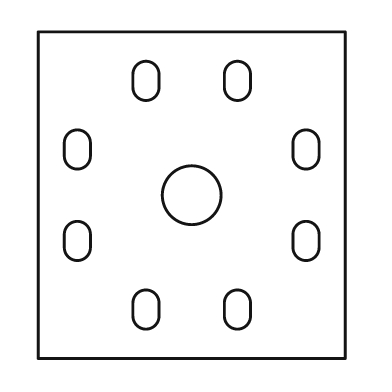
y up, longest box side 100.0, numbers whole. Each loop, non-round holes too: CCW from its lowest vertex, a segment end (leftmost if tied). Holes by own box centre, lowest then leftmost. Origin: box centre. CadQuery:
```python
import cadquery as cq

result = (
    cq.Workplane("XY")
    .moveTo(-47.0, -50.0)
    .lineTo(47.0, -50.0)
    .lineTo(47.0, 50.0)
    .lineTo(-47.0, 50.0)
    .close()
    .moveTo(-18.0, -37.0)
    .threePointArc((-14.0, -41.0), (-10.0, -37.0))
    .lineTo(-10.0, -33.0)
    .threePointArc((-14.0, -29.0), (-18.0, -33.0))
    .close()
    .moveTo(10.0, -37.0)
    .threePointArc((14.0, -41.0), (18.0, -37.0))
    .lineTo(18.0, -33.0)
    .threePointArc((14.0, -29.0), (10.0, -33.0))
    .close()
    .moveTo(-39.0, -16.0)
    .threePointArc((-35.0, -20.0), (-31.0, -16.0))
    .lineTo(-31.0, -12.0)
    .threePointArc((-35.0, -8.0), (-39.0, -12.0))
    .close()
    .moveTo(31.0, -16.0)
    .threePointArc((35.0, -20.0), (39.0, -16.0))
    .lineTo(39.0, -12.0)
    .threePointArc((35.0, -8.0), (31.0, -12.0))
    .close()
    .moveTo(0.0, 0.0)
    .circle(9.0)
    .moveTo(-39.0, 12.0)
    .threePointArc((-35.0, 8.0), (-31.0, 12.0))
    .lineTo(-31.0, 16.0)
    .threePointArc((-35.0, 20.0), (-39.0, 16.0))
    .close()
    .moveTo(31.0, 12.0)
    .threePointArc((35.0, 8.0), (39.0, 12.0))
    .lineTo(39.0, 16.0)
    .threePointArc((35.0, 20.0), (31.0, 16.0))
    .close()
    .moveTo(-18.0, 33.0)
    .threePointArc((-14.0, 29.0), (-10.0, 33.0))
    .lineTo(-10.0, 37.0)
    .threePointArc((-14.0, 41.0), (-18.0, 37.0))
    .close()
    .moveTo(10.0, 33.0)
    .threePointArc((14.0, 29.0), (18.0, 33.0))
    .lineTo(18.0, 37.0)
    .threePointArc((14.0, 41.0), (10.0, 37.0))
    .close()
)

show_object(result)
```